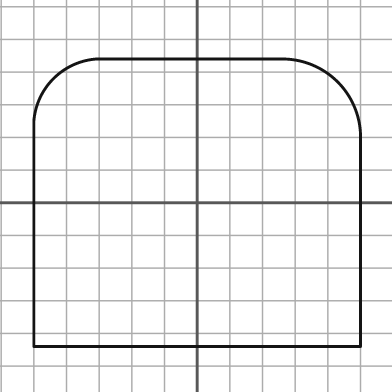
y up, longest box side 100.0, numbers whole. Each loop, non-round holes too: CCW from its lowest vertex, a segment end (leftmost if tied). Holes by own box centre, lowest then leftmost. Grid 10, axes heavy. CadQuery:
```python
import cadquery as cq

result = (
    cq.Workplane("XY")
    .moveTo(-50.0, -44.0)
    .lineTo(50.0, -44.0)
    .lineTo(50.0, 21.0)
    .threePointArc((43.0, 37.0), (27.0, 44.0))
    .lineTo(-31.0, 44.0)
    .threePointArc((-44.0, 38.0), (-50.0, 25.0))
    .close()
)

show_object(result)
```